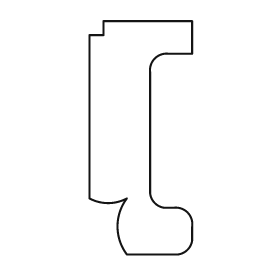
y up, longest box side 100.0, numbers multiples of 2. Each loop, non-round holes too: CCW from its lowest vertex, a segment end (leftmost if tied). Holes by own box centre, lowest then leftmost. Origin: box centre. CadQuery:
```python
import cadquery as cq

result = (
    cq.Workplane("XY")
    .moveTo(-6.0, -50.0)
    .lineTo(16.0, -50.0)
    .threePointArc((20.0, -48.0), (22.0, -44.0))
    .lineTo(22.0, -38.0)
    .threePointArc((20.0, -32.0), (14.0, -30.0))
    .lineTo(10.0, -30.0)
    .threePointArc((6.0, -28.0), (4.0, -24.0))
    .lineTo(4.0, 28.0)
    .threePointArc((6.0, 34.0), (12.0, 36.0))
    .lineTo(22.0, 36.0)
    .lineTo(22.0, 50.0)
    .lineTo(-16.0, 50.0)
    .lineTo(-16.0, 44.0)
    .lineTo(-22.0, 44.0)
    .lineTo(-22.0, -26.0)
    .threePointArc((-14.0, -28.0), (-6.0, -26.0))
    .threePointArc((-10.0, -38.0), (-6.0, -50.0))
    .close()
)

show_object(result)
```